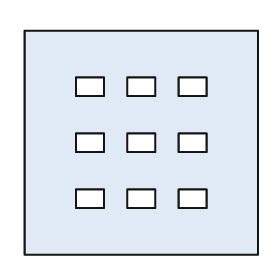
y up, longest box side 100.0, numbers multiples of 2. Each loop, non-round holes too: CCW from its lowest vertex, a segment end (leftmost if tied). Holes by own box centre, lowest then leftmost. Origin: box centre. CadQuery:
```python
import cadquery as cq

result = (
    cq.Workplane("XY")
    .moveTo(-50.0, -48.0)
    .lineTo(50.0, -48.0)
    .lineTo(50.0, 48.0)
    .lineTo(-50.0, 48.0)
    .close()
    .moveTo(-28.0, -28.0)
    .lineTo(-16.0, -28.0)
    .lineTo(-16.0, -20.0)
    .lineTo(-28.0, -20.0)
    .close()
    .moveTo(-6.0, -28.0)
    .lineTo(6.0, -28.0)
    .lineTo(6.0, -20.0)
    .lineTo(-6.0, -20.0)
    .close()
    .moveTo(16.0, -28.0)
    .lineTo(28.0, -28.0)
    .lineTo(28.0, -20.0)
    .lineTo(16.0, -20.0)
    .close()
    .moveTo(-28.0, -4.0)
    .lineTo(-16.0, -4.0)
    .lineTo(-16.0, 4.0)
    .lineTo(-28.0, 4.0)
    .close()
    .moveTo(-6.0, -4.0)
    .lineTo(6.0, -4.0)
    .lineTo(6.0, 4.0)
    .lineTo(-6.0, 4.0)
    .close()
    .moveTo(16.0, -4.0)
    .lineTo(28.0, -4.0)
    .lineTo(28.0, 4.0)
    .lineTo(16.0, 4.0)
    .close()
    .moveTo(-28.0, 20.0)
    .lineTo(-16.0, 20.0)
    .lineTo(-16.0, 28.0)
    .lineTo(-28.0, 28.0)
    .close()
    .moveTo(-6.0, 20.0)
    .lineTo(6.0, 20.0)
    .lineTo(6.0, 28.0)
    .lineTo(-6.0, 28.0)
    .close()
    .moveTo(16.0, 20.0)
    .lineTo(28.0, 20.0)
    .lineTo(28.0, 28.0)
    .lineTo(16.0, 28.0)
    .close()
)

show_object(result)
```